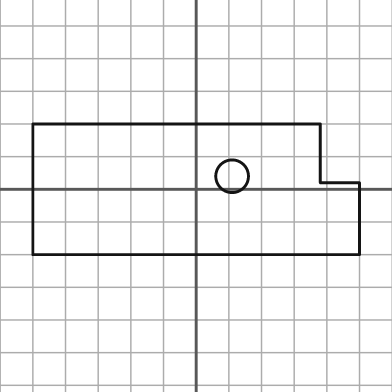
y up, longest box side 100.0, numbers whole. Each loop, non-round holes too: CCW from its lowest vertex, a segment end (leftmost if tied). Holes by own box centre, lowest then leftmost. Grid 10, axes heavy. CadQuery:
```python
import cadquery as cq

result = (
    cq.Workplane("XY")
    .moveTo(-50.0, -20.0)
    .lineTo(50.0, -20.0)
    .lineTo(50.0, 2.0)
    .lineTo(38.0, 2.0)
    .lineTo(38.0, 20.0)
    .lineTo(-50.0, 20.0)
    .close()
    .moveTo(11.0, 4.0)
    .circle(5.0)
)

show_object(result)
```